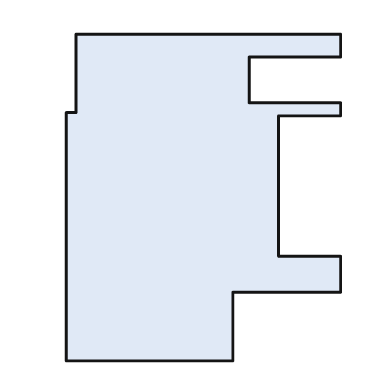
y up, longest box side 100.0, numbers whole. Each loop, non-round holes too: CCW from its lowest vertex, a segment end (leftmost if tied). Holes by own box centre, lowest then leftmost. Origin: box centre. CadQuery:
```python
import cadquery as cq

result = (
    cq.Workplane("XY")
    .moveTo(-42.0, -50.0)
    .lineTo(9.0, -50.0)
    .lineTo(9.0, -29.0)
    .lineTo(42.0, -29.0)
    .lineTo(42.0, -18.0)
    .lineTo(23.0, -18.0)
    .lineTo(23.0, 25.0)
    .lineTo(42.0, 25.0)
    .lineTo(42.0, 29.0)
    .lineTo(14.0, 29.0)
    .lineTo(14.0, 43.0)
    .lineTo(42.0, 43.0)
    .lineTo(42.0, 50.0)
    .lineTo(-39.0, 50.0)
    .lineTo(-39.0, 26.0)
    .lineTo(-42.0, 26.0)
    .close()
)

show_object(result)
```